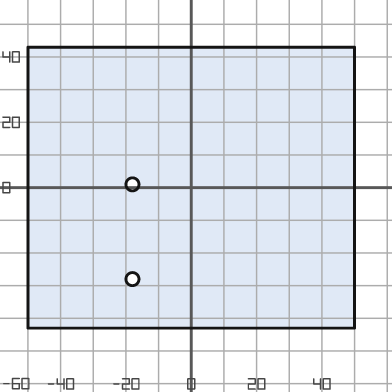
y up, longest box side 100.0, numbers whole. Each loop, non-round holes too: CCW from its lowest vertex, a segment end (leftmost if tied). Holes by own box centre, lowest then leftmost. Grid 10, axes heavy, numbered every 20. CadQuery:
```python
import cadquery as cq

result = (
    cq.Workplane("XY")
    .moveTo(-50.0, -43.0)
    .lineTo(50.0, -43.0)
    .lineTo(50.0, 43.0)
    .lineTo(-50.0, 43.0)
    .close()
    .moveTo(-18.0, -28.0)
    .circle(2.0)
    .moveTo(-18.0, 1.0)
    .circle(2.0)
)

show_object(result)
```